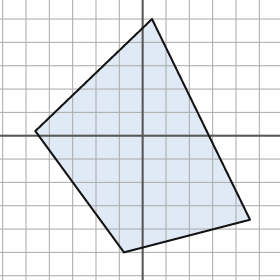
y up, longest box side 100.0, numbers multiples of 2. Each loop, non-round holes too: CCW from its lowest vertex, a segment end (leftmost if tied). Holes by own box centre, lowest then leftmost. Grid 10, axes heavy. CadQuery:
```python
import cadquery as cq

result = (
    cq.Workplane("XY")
    .moveTo(-8.0, -50.0)
    .lineTo(46.0, -36.0)
    .lineTo(4.0, 50.0)
    .lineTo(-46.0, 2.0)
    .close()
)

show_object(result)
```